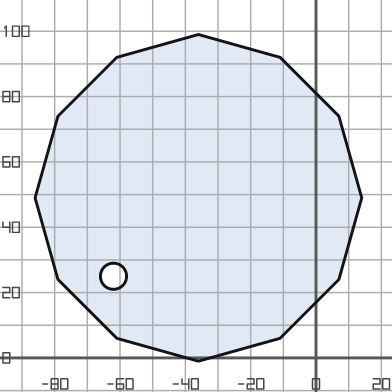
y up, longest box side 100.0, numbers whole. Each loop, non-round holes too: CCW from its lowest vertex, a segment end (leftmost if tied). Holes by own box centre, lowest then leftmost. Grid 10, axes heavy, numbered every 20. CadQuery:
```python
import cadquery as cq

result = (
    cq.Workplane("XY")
    .moveTo(-36.0, -1.0)
    .lineTo(-11.0, 6.0)
    .lineTo(7.0, 24.0)
    .lineTo(14.0, 49.0)
    .lineTo(7.0, 74.0)
    .lineTo(-11.0, 92.0)
    .lineTo(-36.0, 99.0)
    .lineTo(-61.0, 92.0)
    .lineTo(-79.0, 74.0)
    .lineTo(-86.0, 49.0)
    .lineTo(-79.0, 24.0)
    .lineTo(-61.0, 6.0)
    .close()
    .moveTo(-62.0, 25.0)
    .circle(4.0)
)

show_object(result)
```